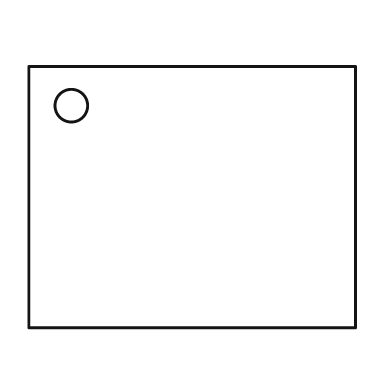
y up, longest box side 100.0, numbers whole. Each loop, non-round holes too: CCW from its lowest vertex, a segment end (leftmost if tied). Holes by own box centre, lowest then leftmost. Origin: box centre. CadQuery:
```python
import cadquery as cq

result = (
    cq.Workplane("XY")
    .moveTo(-50.0, -40.0)
    .lineTo(50.0, -40.0)
    .lineTo(50.0, 40.0)
    .lineTo(-50.0, 40.0)
    .close()
    .moveTo(-37.0, 28.0)
    .circle(5.0)
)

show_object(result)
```